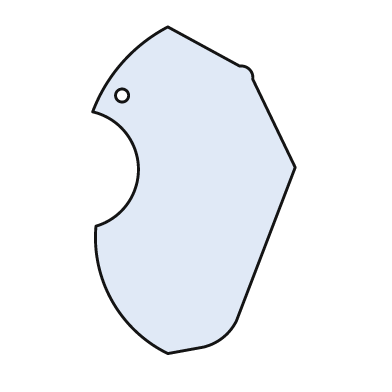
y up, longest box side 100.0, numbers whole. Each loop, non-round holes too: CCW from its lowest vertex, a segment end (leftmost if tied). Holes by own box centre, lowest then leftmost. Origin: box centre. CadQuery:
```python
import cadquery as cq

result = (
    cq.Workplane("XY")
    .moveTo(-8.0, -50.0)
    .lineTo(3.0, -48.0)
    .threePointArc((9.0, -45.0), (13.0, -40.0))
    .lineTo(31.0, 7.0)
    .lineTo(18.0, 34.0)
    .threePointArc((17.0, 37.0), (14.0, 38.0))
    .lineTo(-8.0, 50.0)
    .threePointArc((-22.0, 39.0), (-31.0, 24.0))
    .threePointArc((-17.0, 7.0), (-30.0, -11.0))
    .threePointArc((-25.0, -34.0), (-8.0, -50.0))
    .close()
    .moveTo(-22.0, 29.0)
    .circle(2.0)
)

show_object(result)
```